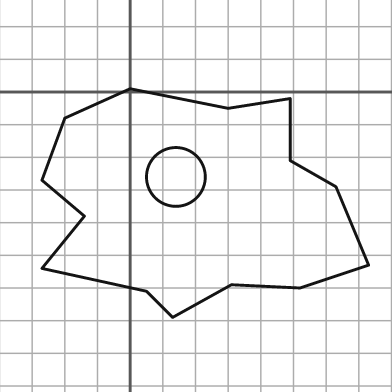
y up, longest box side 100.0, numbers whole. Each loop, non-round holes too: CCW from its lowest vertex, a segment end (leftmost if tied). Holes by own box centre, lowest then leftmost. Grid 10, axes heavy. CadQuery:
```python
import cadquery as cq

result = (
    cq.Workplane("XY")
    .moveTo(13.0, -69.0)
    .lineTo(31.0, -59.0)
    .lineTo(52.0, -60.0)
    .lineTo(73.0, -53.0)
    .lineTo(63.0, -29.0)
    .lineTo(49.0, -21.0)
    .lineTo(49.0, -2.0)
    .lineTo(30.0, -5.0)
    .lineTo(0.0, 1.0)
    .lineTo(-20.0, -8.0)
    .lineTo(-27.0, -27.0)
    .lineTo(-14.0, -38.0)
    .lineTo(-27.0, -54.0)
    .lineTo(5.0, -61.0)
    .close()
    .moveTo(14.0, -26.0)
    .circle(9.0)
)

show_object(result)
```